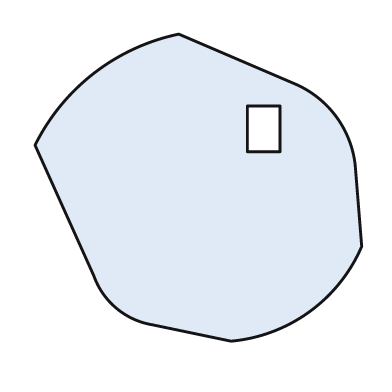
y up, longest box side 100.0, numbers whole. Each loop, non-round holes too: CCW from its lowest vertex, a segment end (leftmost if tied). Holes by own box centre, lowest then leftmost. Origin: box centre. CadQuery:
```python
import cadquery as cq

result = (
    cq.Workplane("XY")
    .moveTo(10.0, -47.0)
    .threePointArc((34.0, -38.0), (50.0, -18.0))
    .lineTo(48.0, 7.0)
    .threePointArc((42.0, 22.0), (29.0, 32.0))
    .lineTo(-6.0, 47.0)
    .threePointArc((-32.0, 35.0), (-50.0, 13.0))
    .lineTo(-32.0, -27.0)
    .threePointArc((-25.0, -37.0), (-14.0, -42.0))
    .close()
    .moveTo(15.0, 11.0)
    .lineTo(25.0, 11.0)
    .lineTo(25.0, 25.0)
    .lineTo(15.0, 25.0)
    .close()
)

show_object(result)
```